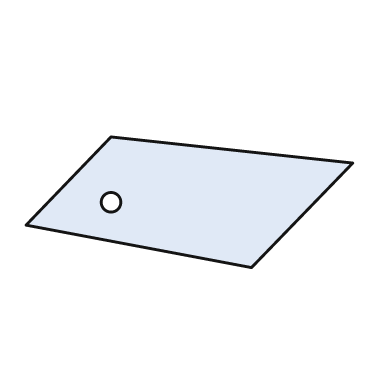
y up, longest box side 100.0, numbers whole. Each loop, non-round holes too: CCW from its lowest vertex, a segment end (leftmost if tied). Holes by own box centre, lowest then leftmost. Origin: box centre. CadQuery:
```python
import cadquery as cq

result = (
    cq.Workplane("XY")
    .moveTo(19.0, -20.0)
    .lineTo(50.0, 12.0)
    .lineTo(-24.0, 20.0)
    .lineTo(-50.0, -7.0)
    .close()
    .moveTo(-24.0, 0.0)
    .circle(3.0)
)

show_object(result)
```